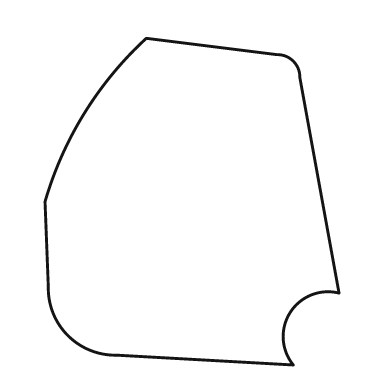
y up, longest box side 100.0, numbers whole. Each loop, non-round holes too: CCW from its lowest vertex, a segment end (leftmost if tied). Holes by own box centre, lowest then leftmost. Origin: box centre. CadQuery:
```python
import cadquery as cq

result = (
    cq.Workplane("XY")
    .moveTo(31.0, -50.0)
    .threePointArc((30.0, -34.0), (45.0, -28.0))
    .lineTo(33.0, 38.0)
    .threePointArc((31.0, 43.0), (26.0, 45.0))
    .lineTo(-14.0, 50.0)
    .threePointArc((-33.0, 27.0), (-45.0, 0.0))
    .lineTo(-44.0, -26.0)
    .threePointArc((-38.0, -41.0), (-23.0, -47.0))
    .close()
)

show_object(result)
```